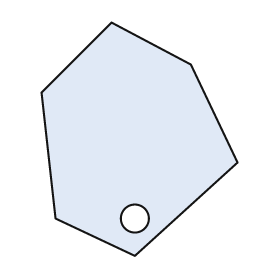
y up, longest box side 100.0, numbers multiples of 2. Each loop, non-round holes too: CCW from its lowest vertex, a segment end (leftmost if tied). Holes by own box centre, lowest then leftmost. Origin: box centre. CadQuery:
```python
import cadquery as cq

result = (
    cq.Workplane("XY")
    .moveTo(-2.0, -50.0)
    .lineTo(42.0, -10.0)
    .lineTo(22.0, 32.0)
    .lineTo(-12.0, 50.0)
    .lineTo(-42.0, 20.0)
    .lineTo(-36.0, -34.0)
    .close()
    .moveTo(-2.0, -34.0)
    .circle(6.0)
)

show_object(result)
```